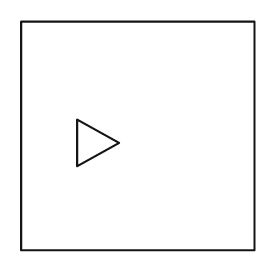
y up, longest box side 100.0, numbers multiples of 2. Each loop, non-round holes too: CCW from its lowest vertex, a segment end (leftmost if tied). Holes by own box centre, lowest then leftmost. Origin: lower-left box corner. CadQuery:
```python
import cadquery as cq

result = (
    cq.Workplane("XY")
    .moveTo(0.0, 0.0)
    .lineTo(100.0, 0.0)
    .lineTo(100.0, 98.0)
    .lineTo(0.0, 98.0)
    .close()
    .moveTo(24.0, 36.0)
    .lineTo(42.0, 46.0)
    .lineTo(24.0, 56.0)
    .close()
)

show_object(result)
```